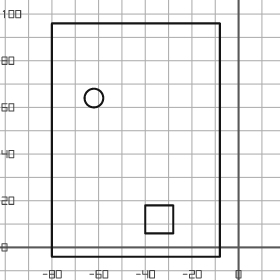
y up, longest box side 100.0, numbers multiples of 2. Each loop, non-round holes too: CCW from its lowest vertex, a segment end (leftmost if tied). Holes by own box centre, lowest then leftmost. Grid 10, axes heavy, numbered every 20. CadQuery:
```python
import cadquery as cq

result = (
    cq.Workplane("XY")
    .moveTo(-80.0, -4.0)
    .lineTo(-8.0, -4.0)
    .lineTo(-8.0, 96.0)
    .lineTo(-80.0, 96.0)
    .close()
    .moveTo(-40.0, 6.0)
    .lineTo(-28.0, 6.0)
    .lineTo(-28.0, 18.0)
    .lineTo(-40.0, 18.0)
    .close()
    .moveTo(-62.0, 64.0)
    .circle(4.0)
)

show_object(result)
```